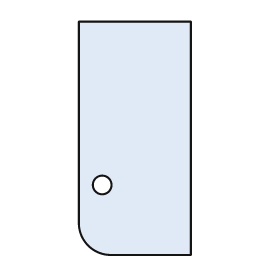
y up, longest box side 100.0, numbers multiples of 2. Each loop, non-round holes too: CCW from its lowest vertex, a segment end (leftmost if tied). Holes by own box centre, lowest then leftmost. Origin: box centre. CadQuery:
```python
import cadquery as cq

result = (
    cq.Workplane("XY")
    .moveTo(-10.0, -50.0)
    .lineTo(24.0, -50.0)
    .lineTo(24.0, 50.0)
    .lineTo(-24.0, 50.0)
    .lineTo(-24.0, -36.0)
    .threePointArc((-20.0, -46.0), (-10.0, -50.0))
    .close()
    .moveTo(-14.0, -20.0)
    .circle(4.0)
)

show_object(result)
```